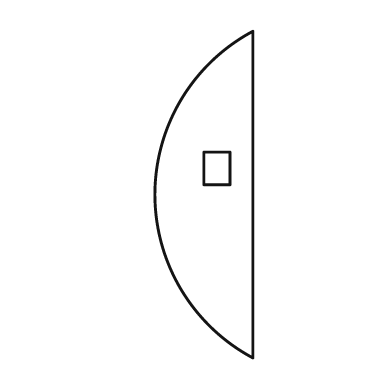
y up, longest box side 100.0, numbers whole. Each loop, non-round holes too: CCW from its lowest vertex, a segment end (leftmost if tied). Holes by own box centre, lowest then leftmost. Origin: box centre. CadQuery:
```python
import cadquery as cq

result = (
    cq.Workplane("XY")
    .moveTo(15.0, -50.0)
    .lineTo(15.0, 50.0)
    .threePointArc((-15.0, 0.0), (15.0, -50.0))
    .close()
    .moveTo(0.0, 3.0)
    .lineTo(8.0, 3.0)
    .lineTo(8.0, 13.0)
    .lineTo(0.0, 13.0)
    .close()
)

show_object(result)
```